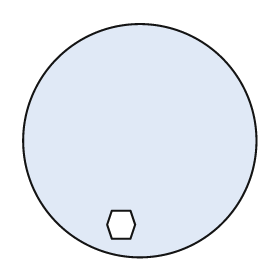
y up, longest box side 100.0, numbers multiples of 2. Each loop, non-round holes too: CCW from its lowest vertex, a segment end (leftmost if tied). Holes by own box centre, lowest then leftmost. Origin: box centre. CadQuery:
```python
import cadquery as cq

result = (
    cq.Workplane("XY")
    .moveTo(0.0, 0.0)
    .circle(50.0)
    .moveTo(-12.0, -42.0)
    .lineTo(-4.0, -42.0)
    .lineTo(-2.0, -36.0)
    .lineTo(-4.0, -30.0)
    .lineTo(-12.0, -30.0)
    .lineTo(-14.0, -36.0)
    .close()
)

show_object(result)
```